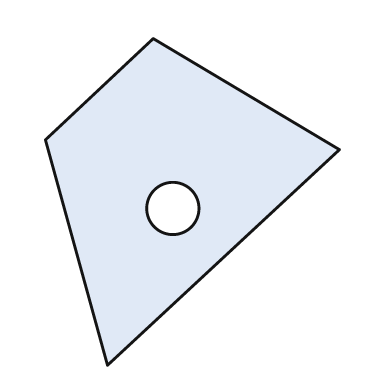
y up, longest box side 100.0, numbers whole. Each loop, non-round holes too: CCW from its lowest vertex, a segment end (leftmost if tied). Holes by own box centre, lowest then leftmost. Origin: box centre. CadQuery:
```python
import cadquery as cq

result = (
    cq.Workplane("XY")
    .moveTo(-26.0, -50.0)
    .lineTo(45.0, 16.0)
    .lineTo(-12.0, 50.0)
    .lineTo(-45.0, 19.0)
    .close()
    .moveTo(-6.0, -2.0)
    .circle(8.0)
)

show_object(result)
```